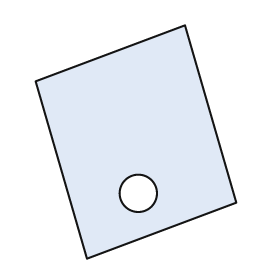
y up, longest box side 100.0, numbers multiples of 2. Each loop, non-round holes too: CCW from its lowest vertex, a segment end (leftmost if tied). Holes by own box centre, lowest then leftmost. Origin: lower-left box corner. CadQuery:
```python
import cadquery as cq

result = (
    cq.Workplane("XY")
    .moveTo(22.0, 0.0)
    .lineTo(86.0, 24.0)
    .lineTo(64.0, 100.0)
    .lineTo(0.0, 76.0)
    .close()
    .moveTo(44.0, 28.0)
    .circle(8.0)
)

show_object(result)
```